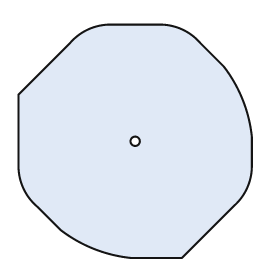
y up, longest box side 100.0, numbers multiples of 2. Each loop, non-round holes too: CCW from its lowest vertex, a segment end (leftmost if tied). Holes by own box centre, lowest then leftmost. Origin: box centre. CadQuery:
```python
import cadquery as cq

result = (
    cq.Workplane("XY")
    .moveTo(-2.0, -50.0)
    .lineTo(20.0, -50.0)
    .lineTo(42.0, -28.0)
    .threePointArc((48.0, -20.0), (50.0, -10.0))
    .lineTo(50.0, 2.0)
    .threePointArc((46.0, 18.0), (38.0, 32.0))
    .lineTo(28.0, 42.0)
    .threePointArc((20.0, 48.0), (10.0, 50.0))
    .lineTo(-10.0, 50.0)
    .threePointArc((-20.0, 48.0), (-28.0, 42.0))
    .lineTo(-50.0, 20.0)
    .lineTo(-50.0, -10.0)
    .threePointArc((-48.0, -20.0), (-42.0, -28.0))
    .lineTo(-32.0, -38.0)
    .threePointArc((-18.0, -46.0), (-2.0, -50.0))
    .close()
    .moveTo(0.0, 0.0)
    .circle(2.0)
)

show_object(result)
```